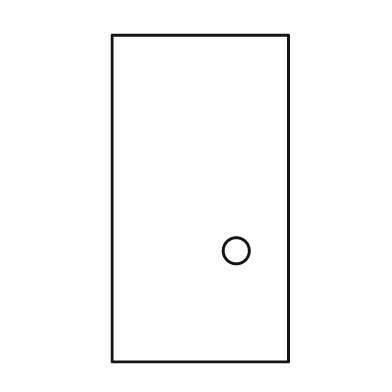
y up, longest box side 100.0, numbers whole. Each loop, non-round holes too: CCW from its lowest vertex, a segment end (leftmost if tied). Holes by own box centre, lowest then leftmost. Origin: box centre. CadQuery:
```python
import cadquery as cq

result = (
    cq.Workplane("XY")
    .moveTo(-27.0, -50.0)
    .lineTo(27.0, -50.0)
    .lineTo(27.0, 50.0)
    .lineTo(-27.0, 50.0)
    .close()
    .moveTo(11.0, -16.0)
    .circle(4.0)
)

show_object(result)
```